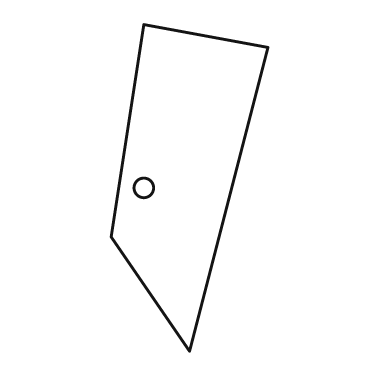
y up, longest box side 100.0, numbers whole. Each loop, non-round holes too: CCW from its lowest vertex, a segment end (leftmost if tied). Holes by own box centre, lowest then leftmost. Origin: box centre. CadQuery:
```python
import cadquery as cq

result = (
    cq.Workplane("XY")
    .moveTo(0.0, -50.0)
    .lineTo(24.0, 43.0)
    .lineTo(-14.0, 50.0)
    .lineTo(-24.0, -15.0)
    .close()
    .moveTo(-14.0, 0.0)
    .circle(3.0)
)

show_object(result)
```